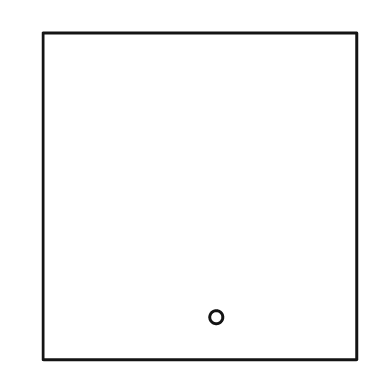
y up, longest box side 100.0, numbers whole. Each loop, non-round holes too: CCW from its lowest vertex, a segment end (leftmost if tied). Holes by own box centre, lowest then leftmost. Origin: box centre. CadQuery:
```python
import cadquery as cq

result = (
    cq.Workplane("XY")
    .moveTo(-48.0, -50.0)
    .lineTo(48.0, -50.0)
    .lineTo(48.0, 50.0)
    .lineTo(-48.0, 50.0)
    .close()
    .moveTo(5.0, -37.0)
    .circle(2.0)
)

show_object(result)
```